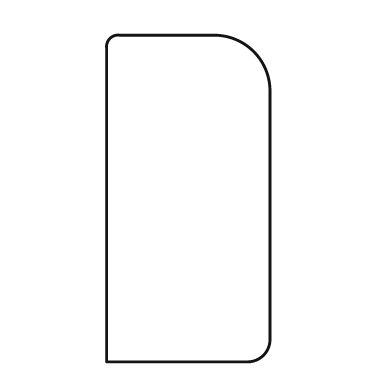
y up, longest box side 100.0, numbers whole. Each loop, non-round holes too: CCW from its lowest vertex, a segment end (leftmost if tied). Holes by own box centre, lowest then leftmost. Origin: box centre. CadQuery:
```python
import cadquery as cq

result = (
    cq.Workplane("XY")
    .moveTo(-25.0, -50.0)
    .lineTo(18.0, -50.0)
    .threePointArc((23.0, -48.0), (25.0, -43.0))
    .lineTo(25.0, 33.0)
    .threePointArc((20.0, 45.0), (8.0, 50.0))
    .lineTo(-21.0, 50.0)
    .threePointArc((-24.0, 49.0), (-25.0, 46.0))
    .close()
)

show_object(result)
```